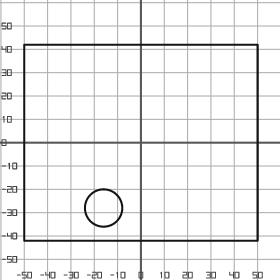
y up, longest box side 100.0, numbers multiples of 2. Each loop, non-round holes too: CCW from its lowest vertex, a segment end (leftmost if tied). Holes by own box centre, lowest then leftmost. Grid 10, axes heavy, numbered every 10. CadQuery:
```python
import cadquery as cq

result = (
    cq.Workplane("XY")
    .moveTo(-50.0, -42.0)
    .lineTo(50.0, -42.0)
    .lineTo(50.0, 42.0)
    .lineTo(-50.0, 42.0)
    .close()
    .moveTo(-16.0, -28.0)
    .circle(8.0)
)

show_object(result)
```